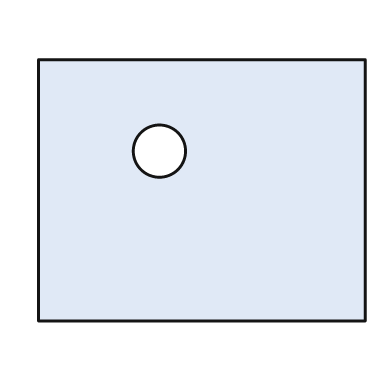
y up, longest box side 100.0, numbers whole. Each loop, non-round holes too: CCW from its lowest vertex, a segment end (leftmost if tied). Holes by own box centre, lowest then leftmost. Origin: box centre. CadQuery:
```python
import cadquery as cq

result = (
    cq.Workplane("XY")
    .moveTo(-50.0, -40.0)
    .lineTo(50.0, -40.0)
    .lineTo(50.0, 40.0)
    .lineTo(-50.0, 40.0)
    .close()
    .moveTo(-13.0, 12.0)
    .circle(8.0)
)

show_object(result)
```